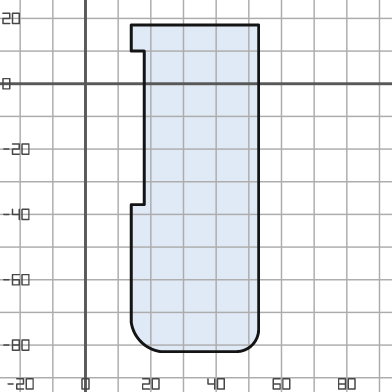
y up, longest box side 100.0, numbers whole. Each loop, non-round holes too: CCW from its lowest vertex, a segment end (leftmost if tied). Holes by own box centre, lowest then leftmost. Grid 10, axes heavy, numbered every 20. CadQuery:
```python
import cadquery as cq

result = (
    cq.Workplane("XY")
    .moveTo(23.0, -82.0)
    .lineTo(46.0, -82.0)
    .threePointArc((51.0, -80.0), (53.0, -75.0))
    .lineTo(53.0, 18.0)
    .lineTo(14.0, 18.0)
    .lineTo(14.0, 10.0)
    .lineTo(18.0, 10.0)
    .lineTo(18.0, -37.0)
    .lineTo(14.0, -37.0)
    .lineTo(14.0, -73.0)
    .threePointArc((17.0, -79.0), (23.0, -82.0))
    .close()
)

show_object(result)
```